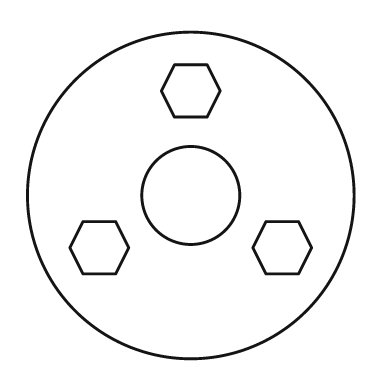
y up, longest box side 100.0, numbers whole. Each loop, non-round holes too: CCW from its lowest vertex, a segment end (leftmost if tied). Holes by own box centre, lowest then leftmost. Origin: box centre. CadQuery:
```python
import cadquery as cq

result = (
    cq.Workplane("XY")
    .moveTo(0.0, 0.0)
    .circle(50.0)
    .moveTo(-33.0, -24.0)
    .lineTo(-23.0, -24.0)
    .lineTo(-19.0, -16.0)
    .lineTo(-23.0, -8.0)
    .lineTo(-33.0, -8.0)
    .lineTo(-37.0, -16.0)
    .close()
    .moveTo(23.0, -24.0)
    .lineTo(33.0, -24.0)
    .lineTo(37.0, -16.0)
    .lineTo(33.0, -8.0)
    .lineTo(23.0, -8.0)
    .lineTo(19.0, -16.0)
    .close()
    .moveTo(0.0, 0.0)
    .circle(15.0)
    .moveTo(-5.0, 24.0)
    .lineTo(5.0, 24.0)
    .lineTo(9.0, 32.0)
    .lineTo(5.0, 40.0)
    .lineTo(-5.0, 40.0)
    .lineTo(-9.0, 32.0)
    .close()
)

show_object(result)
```